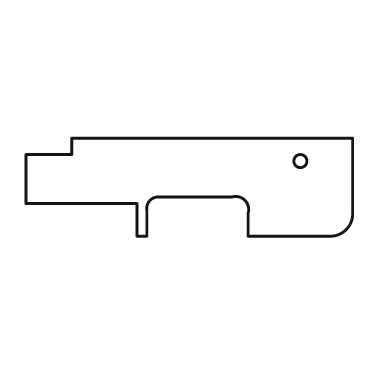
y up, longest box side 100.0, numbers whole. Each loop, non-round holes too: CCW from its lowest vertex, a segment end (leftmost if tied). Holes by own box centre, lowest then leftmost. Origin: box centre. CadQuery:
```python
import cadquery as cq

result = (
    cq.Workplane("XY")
    .moveTo(-16.0, -15.0)
    .lineTo(-13.0, -15.0)
    .lineTo(-13.0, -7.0)
    .threePointArc((-12.0, -4.0), (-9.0, -3.0))
    .lineTo(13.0, -3.0)
    .threePointArc((17.0, -4.0), (18.0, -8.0))
    .lineTo(18.0, -15.0)
    .lineTo(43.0, -15.0)
    .threePointArc((48.0, -13.0), (50.0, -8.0))
    .lineTo(50.0, 15.0)
    .lineTo(-36.0, 15.0)
    .lineTo(-36.0, 10.0)
    .lineTo(-50.0, 10.0)
    .lineTo(-50.0, -5.0)
    .lineTo(-16.0, -5.0)
    .close()
    .moveTo(34.0, 8.0)
    .circle(2.0)
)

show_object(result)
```